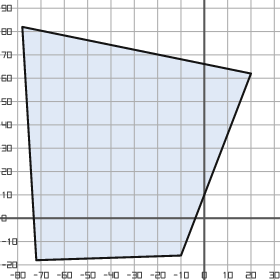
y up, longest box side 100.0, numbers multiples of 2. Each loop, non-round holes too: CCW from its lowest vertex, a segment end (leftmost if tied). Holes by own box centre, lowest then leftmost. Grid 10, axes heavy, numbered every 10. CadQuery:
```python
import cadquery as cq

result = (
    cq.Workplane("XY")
    .moveTo(-72.0, -18.0)
    .lineTo(-10.0, -16.0)
    .lineTo(20.0, 62.0)
    .lineTo(-78.0, 82.0)
    .close()
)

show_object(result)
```